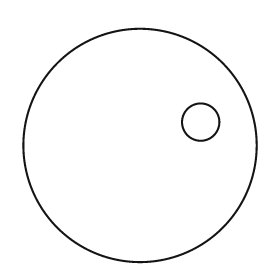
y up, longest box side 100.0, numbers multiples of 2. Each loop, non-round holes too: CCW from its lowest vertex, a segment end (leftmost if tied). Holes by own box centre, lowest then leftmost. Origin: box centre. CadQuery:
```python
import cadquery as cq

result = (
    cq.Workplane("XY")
    .moveTo(0.0, 0.0)
    .circle(50.0)
    .moveTo(26.0, 10.0)
    .circle(8.0)
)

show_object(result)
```